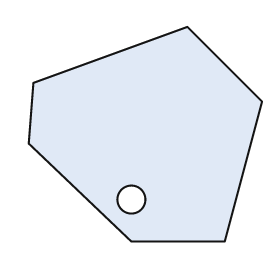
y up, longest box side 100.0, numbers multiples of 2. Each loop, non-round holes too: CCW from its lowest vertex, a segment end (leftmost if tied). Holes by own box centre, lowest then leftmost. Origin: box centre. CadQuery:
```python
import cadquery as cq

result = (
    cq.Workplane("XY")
    .moveTo(-6.0, -46.0)
    .lineTo(34.0, -46.0)
    .lineTo(50.0, 14.0)
    .lineTo(18.0, 46.0)
    .lineTo(-48.0, 22.0)
    .lineTo(-50.0, -4.0)
    .close()
    .moveTo(-6.0, -28.0)
    .circle(6.0)
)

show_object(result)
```